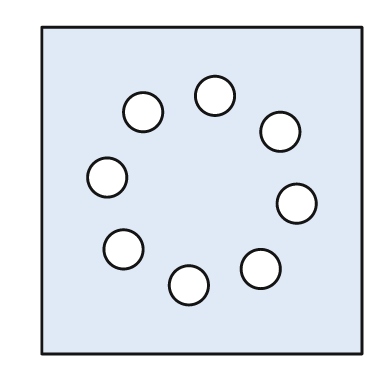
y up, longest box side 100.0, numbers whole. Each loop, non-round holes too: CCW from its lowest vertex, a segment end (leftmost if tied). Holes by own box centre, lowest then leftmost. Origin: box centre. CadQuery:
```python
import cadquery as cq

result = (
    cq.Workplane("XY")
    .moveTo(-49.0, -50.0)
    .lineTo(49.0, -50.0)
    .lineTo(49.0, 50.0)
    .lineTo(-49.0, 50.0)
    .close()
    .moveTo(-4.0, -29.0)
    .circle(6.0)
    .moveTo(18.0, -24.0)
    .circle(6.0)
    .moveTo(-24.0, -18.0)
    .circle(6.0)
    .moveTo(29.0, -4.0)
    .circle(6.0)
    .moveTo(-29.0, 4.0)
    .circle(6.0)
    .moveTo(24.0, 18.0)
    .circle(6.0)
    .moveTo(-18.0, 24.0)
    .circle(6.0)
    .moveTo(4.0, 29.0)
    .circle(6.0)
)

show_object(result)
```